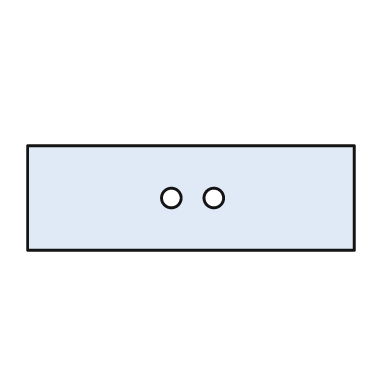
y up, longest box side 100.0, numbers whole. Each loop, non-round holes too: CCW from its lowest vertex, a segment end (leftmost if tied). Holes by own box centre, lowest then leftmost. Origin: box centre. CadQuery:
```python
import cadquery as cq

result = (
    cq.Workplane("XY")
    .moveTo(-50.0, -16.0)
    .lineTo(50.0, -16.0)
    .lineTo(50.0, 16.0)
    .lineTo(-50.0, 16.0)
    .close()
    .moveTo(-6.0, 0.0)
    .circle(3.0)
    .moveTo(7.0, 0.0)
    .circle(3.0)
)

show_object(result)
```